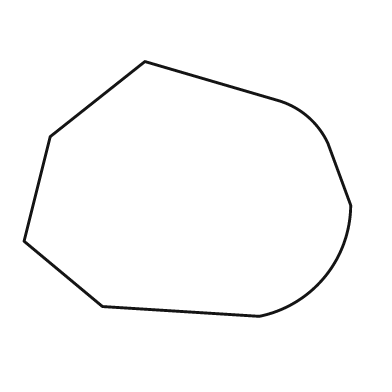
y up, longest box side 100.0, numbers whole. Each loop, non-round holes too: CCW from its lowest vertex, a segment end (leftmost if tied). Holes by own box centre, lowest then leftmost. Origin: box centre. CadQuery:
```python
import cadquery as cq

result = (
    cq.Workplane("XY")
    .moveTo(22.0, -39.0)
    .threePointArc((42.0, -27.0), (50.0, -5.0))
    .lineTo(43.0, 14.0)
    .threePointArc((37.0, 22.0), (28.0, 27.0))
    .lineTo(-13.0, 39.0)
    .lineTo(-42.0, 16.0)
    .lineTo(-50.0, -16.0)
    .lineTo(-26.0, -36.0)
    .close()
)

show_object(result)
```